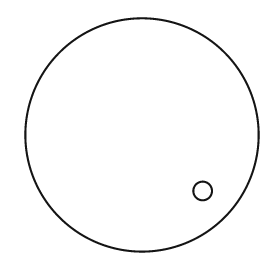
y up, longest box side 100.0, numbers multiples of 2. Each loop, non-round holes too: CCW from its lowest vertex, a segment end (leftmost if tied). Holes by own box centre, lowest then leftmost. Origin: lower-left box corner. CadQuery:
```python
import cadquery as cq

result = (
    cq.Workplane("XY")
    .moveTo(50.0, 50.0)
    .circle(50.0)
    .moveTo(76.0, 26.0)
    .circle(4.0)
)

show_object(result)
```